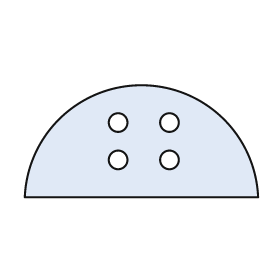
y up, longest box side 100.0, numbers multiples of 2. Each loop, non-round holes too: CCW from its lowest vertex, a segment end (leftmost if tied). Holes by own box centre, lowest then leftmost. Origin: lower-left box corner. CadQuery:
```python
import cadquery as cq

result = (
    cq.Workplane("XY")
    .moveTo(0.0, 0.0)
    .lineTo(100.0, 0.0)
    .threePointArc((50.0, 48.0), (0.0, 0.0))
    .close()
    .moveTo(40.0, 16.0)
    .circle(4.0)
    .moveTo(62.0, 16.0)
    .circle(4.0)
    .moveTo(40.0, 32.0)
    .circle(4.0)
    .moveTo(62.0, 32.0)
    .circle(4.0)
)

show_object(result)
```